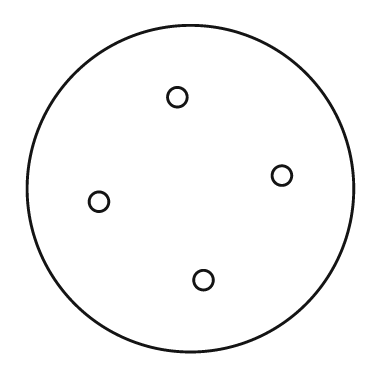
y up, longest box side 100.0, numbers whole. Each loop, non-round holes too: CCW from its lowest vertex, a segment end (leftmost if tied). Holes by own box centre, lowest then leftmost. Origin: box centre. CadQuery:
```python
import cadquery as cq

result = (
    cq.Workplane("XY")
    .moveTo(0.0, 0.0)
    .circle(50.0)
    .moveTo(4.0, -28.0)
    .circle(3.0)
    .moveTo(-28.0, -4.0)
    .circle(3.0)
    .moveTo(28.0, 4.0)
    .circle(3.0)
    .moveTo(-4.0, 28.0)
    .circle(3.0)
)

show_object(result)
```